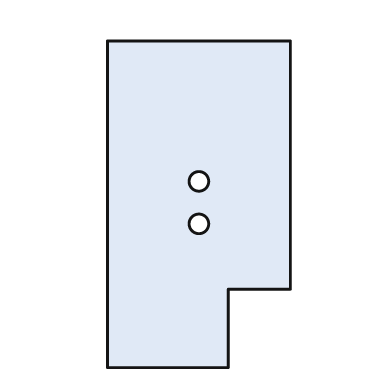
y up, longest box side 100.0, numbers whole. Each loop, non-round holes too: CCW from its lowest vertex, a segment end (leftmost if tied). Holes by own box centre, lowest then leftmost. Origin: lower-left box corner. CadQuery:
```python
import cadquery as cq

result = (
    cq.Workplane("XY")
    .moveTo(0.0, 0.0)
    .lineTo(37.0, 0.0)
    .lineTo(37.0, 24.0)
    .lineTo(56.0, 24.0)
    .lineTo(56.0, 100.0)
    .lineTo(0.0, 100.0)
    .close()
    .moveTo(28.0, 44.0)
    .circle(3.0)
    .moveTo(28.0, 57.0)
    .circle(3.0)
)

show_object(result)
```